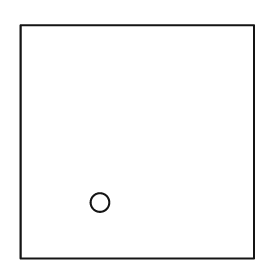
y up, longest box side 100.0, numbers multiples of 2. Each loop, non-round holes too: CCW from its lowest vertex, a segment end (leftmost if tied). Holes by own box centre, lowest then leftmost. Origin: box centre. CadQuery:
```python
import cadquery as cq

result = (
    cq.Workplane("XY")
    .moveTo(-50.0, -50.0)
    .lineTo(50.0, -50.0)
    .lineTo(50.0, 50.0)
    .lineTo(-50.0, 50.0)
    .close()
    .moveTo(-16.0, -26.0)
    .circle(4.0)
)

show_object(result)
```